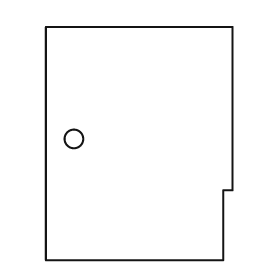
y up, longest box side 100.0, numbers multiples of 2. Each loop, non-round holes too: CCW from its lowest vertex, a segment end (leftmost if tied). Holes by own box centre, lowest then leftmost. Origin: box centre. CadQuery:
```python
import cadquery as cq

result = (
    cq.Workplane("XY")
    .moveTo(-40.0, -50.0)
    .lineTo(36.0, -50.0)
    .lineTo(36.0, -20.0)
    .lineTo(40.0, -20.0)
    .lineTo(40.0, 50.0)
    .lineTo(-40.0, 50.0)
    .close()
    .moveTo(-28.0, 2.0)
    .circle(4.0)
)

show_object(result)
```